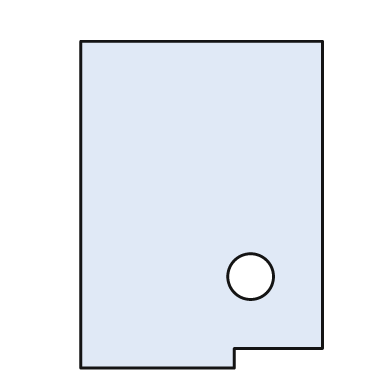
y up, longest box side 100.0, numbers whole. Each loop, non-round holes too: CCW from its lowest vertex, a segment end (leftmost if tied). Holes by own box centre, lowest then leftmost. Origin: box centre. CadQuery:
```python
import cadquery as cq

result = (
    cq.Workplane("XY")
    .moveTo(-37.0, -50.0)
    .lineTo(10.0, -50.0)
    .lineTo(10.0, -44.0)
    .lineTo(37.0, -44.0)
    .lineTo(37.0, 50.0)
    .lineTo(-37.0, 50.0)
    .close()
    .moveTo(15.0, -22.0)
    .circle(7.0)
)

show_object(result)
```